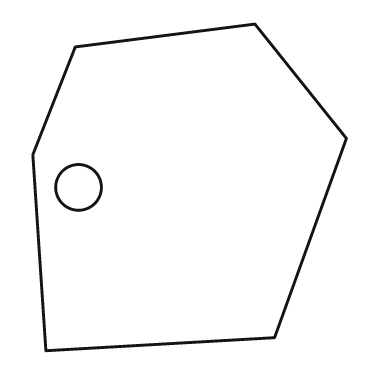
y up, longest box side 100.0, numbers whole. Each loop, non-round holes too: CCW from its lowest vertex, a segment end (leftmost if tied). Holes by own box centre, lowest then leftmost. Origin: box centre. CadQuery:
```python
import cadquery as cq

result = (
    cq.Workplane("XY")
    .moveTo(-44.0, -50.0)
    .lineTo(26.0, -46.0)
    .lineTo(48.0, 15.0)
    .lineTo(20.0, 50.0)
    .lineTo(-35.0, 43.0)
    .lineTo(-48.0, 10.0)
    .close()
    .moveTo(-34.0, 0.0)
    .circle(7.0)
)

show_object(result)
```